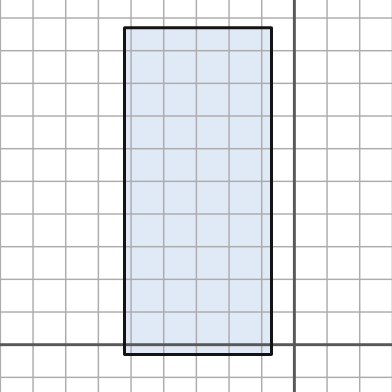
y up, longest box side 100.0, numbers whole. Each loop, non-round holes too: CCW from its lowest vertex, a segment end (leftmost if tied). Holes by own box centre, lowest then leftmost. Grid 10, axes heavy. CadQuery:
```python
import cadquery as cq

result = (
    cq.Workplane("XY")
    .moveTo(-52.0, -3.0)
    .lineTo(-7.0, -3.0)
    .lineTo(-7.0, 97.0)
    .lineTo(-52.0, 97.0)
    .close()
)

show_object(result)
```